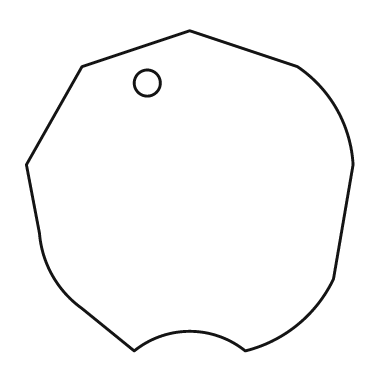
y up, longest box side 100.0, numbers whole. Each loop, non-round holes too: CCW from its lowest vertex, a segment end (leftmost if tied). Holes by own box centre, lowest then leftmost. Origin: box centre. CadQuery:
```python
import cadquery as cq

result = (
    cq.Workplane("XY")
    .moveTo(-17.0, -49.0)
    .threePointArc((0.0, -43.0), (17.0, -49.0))
    .threePointArc((33.0, -41.0), (44.0, -27.0))
    .lineTo(50.0, 8.0)
    .threePointArc((45.0, 25.0), (33.0, 38.0))
    .lineTo(0.0, 49.0)
    .lineTo(-33.0, 38.0)
    .lineTo(-50.0, 8.0)
    .lineTo(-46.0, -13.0)
    .threePointArc((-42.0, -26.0), (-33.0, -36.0))
    .close()
    .moveTo(-13.0, 33.0)
    .circle(4.0)
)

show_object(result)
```